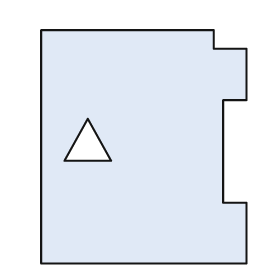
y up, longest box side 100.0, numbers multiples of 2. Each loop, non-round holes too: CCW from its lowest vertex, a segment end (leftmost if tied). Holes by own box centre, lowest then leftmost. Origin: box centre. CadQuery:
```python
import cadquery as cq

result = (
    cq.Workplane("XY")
    .moveTo(-44.0, -50.0)
    .lineTo(44.0, -50.0)
    .lineTo(44.0, -24.0)
    .lineTo(34.0, -24.0)
    .lineTo(34.0, 20.0)
    .lineTo(44.0, 20.0)
    .lineTo(44.0, 42.0)
    .lineTo(30.0, 42.0)
    .lineTo(30.0, 50.0)
    .lineTo(-44.0, 50.0)
    .close()
    .moveTo(-34.0, -6.0)
    .lineTo(-14.0, -6.0)
    .lineTo(-24.0, 12.0)
    .close()
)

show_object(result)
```